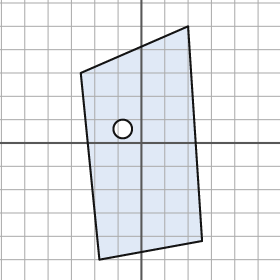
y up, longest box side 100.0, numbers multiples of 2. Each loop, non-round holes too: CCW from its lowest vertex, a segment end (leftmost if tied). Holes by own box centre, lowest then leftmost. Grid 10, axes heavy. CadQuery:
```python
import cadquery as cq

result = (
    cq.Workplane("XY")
    .moveTo(-18.0, -50.0)
    .lineTo(26.0, -42.0)
    .lineTo(20.0, 50.0)
    .lineTo(-26.0, 30.0)
    .close()
    .moveTo(-8.0, 6.0)
    .circle(4.0)
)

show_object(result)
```